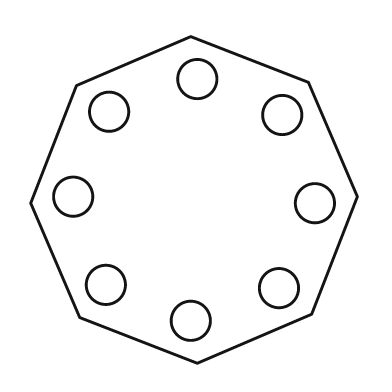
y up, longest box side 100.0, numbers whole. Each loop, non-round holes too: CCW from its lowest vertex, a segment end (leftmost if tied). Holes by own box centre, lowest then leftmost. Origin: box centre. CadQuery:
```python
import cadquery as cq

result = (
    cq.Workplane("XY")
    .moveTo(1.0, -50.0)
    .lineTo(36.0, -35.0)
    .lineTo(50.0, 1.0)
    .lineTo(35.0, 36.0)
    .lineTo(-1.0, 50.0)
    .lineTo(-36.0, 35.0)
    .lineTo(-50.0, -1.0)
    .lineTo(-35.0, -36.0)
    .close()
    .moveTo(-1.0, -37.0)
    .circle(6.0)
    .moveTo(26.0, -27.0)
    .circle(6.0)
    .moveTo(-27.0, -26.0)
    .circle(6.0)
    .moveTo(37.0, -1.0)
    .circle(6.0)
    .moveTo(-37.0, 1.0)
    .circle(6.0)
    .moveTo(27.0, 26.0)
    .circle(6.0)
    .moveTo(-26.0, 27.0)
    .circle(6.0)
    .moveTo(1.0, 37.0)
    .circle(6.0)
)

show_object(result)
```